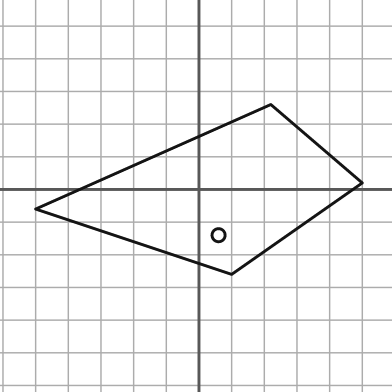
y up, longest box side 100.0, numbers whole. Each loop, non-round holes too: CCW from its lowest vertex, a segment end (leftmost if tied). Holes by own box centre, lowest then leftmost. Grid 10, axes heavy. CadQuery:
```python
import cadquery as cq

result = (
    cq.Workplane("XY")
    .moveTo(10.0, -26.0)
    .lineTo(50.0, 2.0)
    .lineTo(22.0, 26.0)
    .lineTo(-50.0, -6.0)
    .close()
    .moveTo(6.0, -14.0)
    .circle(2.0)
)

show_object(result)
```